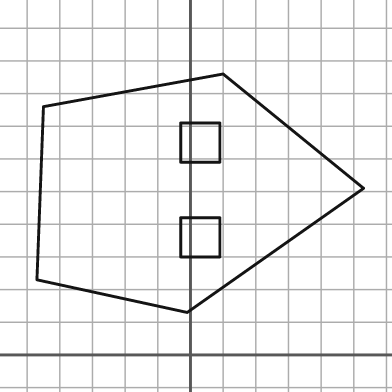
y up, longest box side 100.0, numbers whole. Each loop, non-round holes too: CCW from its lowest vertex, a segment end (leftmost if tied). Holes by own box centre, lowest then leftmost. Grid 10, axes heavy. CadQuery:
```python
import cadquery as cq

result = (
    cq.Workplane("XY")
    .moveTo(-1.0, 13.0)
    .lineTo(53.0, 51.0)
    .lineTo(10.0, 86.0)
    .lineTo(-45.0, 76.0)
    .lineTo(-47.0, 23.0)
    .close()
    .moveTo(-3.0, 30.0)
    .lineTo(9.0, 30.0)
    .lineTo(9.0, 42.0)
    .lineTo(-3.0, 42.0)
    .close()
    .moveTo(-3.0, 59.0)
    .lineTo(9.0, 59.0)
    .lineTo(9.0, 71.0)
    .lineTo(-3.0, 71.0)
    .close()
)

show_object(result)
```